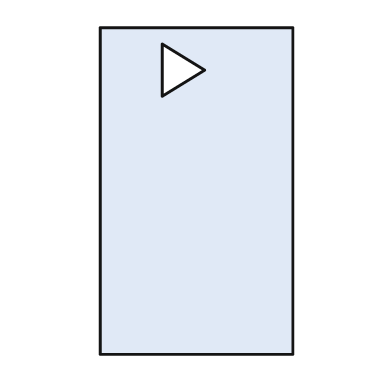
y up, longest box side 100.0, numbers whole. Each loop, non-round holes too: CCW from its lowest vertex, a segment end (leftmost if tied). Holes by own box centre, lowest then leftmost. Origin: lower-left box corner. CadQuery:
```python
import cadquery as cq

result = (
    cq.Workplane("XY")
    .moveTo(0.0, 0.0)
    .lineTo(59.0, 0.0)
    .lineTo(59.0, 100.0)
    .lineTo(0.0, 100.0)
    .close()
    .moveTo(19.0, 79.0)
    .lineTo(32.0, 87.0)
    .lineTo(19.0, 95.0)
    .close()
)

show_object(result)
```